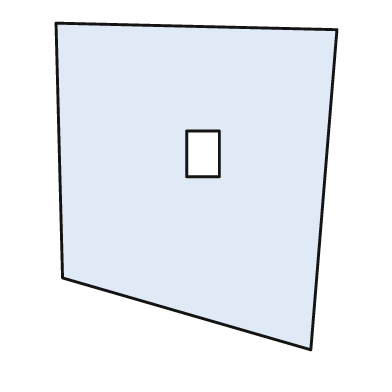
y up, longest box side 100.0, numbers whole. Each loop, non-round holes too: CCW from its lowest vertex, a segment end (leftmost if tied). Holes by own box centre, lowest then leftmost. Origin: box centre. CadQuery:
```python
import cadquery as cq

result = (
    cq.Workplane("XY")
    .moveTo(35.0, -50.0)
    .lineTo(43.0, 48.0)
    .lineTo(-43.0, 50.0)
    .lineTo(-41.0, -28.0)
    .close()
    .moveTo(-3.0, 3.0)
    .lineTo(7.0, 3.0)
    .lineTo(7.0, 17.0)
    .lineTo(-3.0, 17.0)
    .close()
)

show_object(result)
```